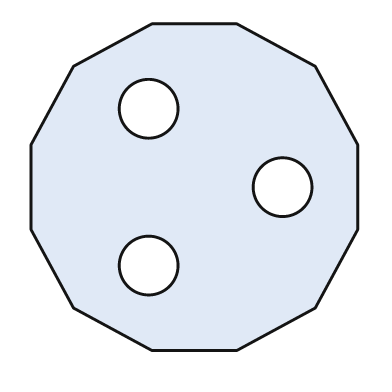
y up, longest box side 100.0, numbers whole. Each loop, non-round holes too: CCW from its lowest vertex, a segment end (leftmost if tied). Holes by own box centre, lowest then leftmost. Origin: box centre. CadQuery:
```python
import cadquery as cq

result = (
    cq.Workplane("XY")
    .moveTo(-13.0, -50.0)
    .lineTo(13.0, -50.0)
    .lineTo(37.0, -37.0)
    .lineTo(50.0, -13.0)
    .lineTo(50.0, 13.0)
    .lineTo(37.0, 37.0)
    .lineTo(13.0, 50.0)
    .lineTo(-13.0, 50.0)
    .lineTo(-37.0, 37.0)
    .lineTo(-50.0, 13.0)
    .lineTo(-50.0, -13.0)
    .lineTo(-37.0, -37.0)
    .close()
    .moveTo(-14.0, -24.0)
    .circle(9.0)
    .moveTo(27.0, 0.0)
    .circle(9.0)
    .moveTo(-14.0, 24.0)
    .circle(9.0)
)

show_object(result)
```